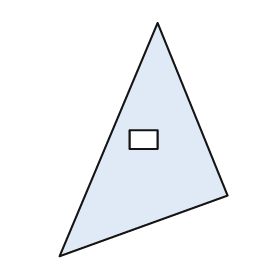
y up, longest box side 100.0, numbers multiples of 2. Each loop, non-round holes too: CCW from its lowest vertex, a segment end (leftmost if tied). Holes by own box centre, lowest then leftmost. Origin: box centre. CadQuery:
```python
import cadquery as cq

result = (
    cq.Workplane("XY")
    .moveTo(-36.0, -50.0)
    .lineTo(36.0, -24.0)
    .lineTo(6.0, 50.0)
    .close()
    .moveTo(-6.0, -4.0)
    .lineTo(6.0, -4.0)
    .lineTo(6.0, 4.0)
    .lineTo(-6.0, 4.0)
    .close()
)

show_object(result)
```